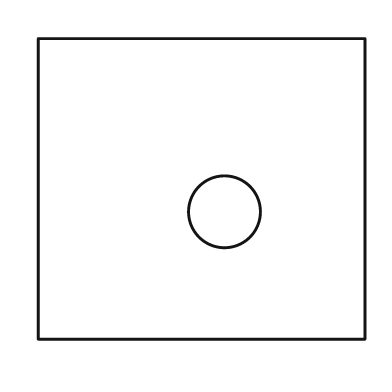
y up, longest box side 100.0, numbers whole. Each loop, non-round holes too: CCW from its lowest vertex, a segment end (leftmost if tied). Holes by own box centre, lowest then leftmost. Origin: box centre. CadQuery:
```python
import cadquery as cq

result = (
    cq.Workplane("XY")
    .moveTo(-50.0, -46.0)
    .lineTo(50.0, -46.0)
    .lineTo(50.0, 46.0)
    .lineTo(-50.0, 46.0)
    .close()
    .moveTo(7.0, -7.0)
    .circle(11.0)
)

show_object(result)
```